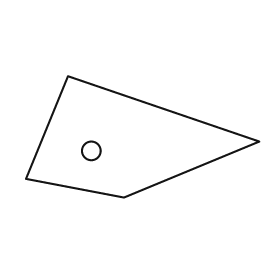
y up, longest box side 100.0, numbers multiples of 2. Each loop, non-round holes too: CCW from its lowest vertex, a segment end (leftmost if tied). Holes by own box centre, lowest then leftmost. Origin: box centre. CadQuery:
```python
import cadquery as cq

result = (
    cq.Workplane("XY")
    .moveTo(-8.0, -26.0)
    .lineTo(50.0, -2.0)
    .lineTo(-32.0, 26.0)
    .lineTo(-50.0, -18.0)
    .close()
    .moveTo(-22.0, -6.0)
    .circle(4.0)
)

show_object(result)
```